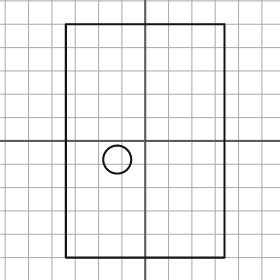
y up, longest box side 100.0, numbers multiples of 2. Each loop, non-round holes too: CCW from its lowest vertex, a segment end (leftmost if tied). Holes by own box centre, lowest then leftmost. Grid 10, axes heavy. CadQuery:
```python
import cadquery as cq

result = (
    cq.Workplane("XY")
    .moveTo(-34.0, -50.0)
    .lineTo(34.0, -50.0)
    .lineTo(34.0, 50.0)
    .lineTo(-34.0, 50.0)
    .close()
    .moveTo(-12.0, -8.0)
    .circle(6.0)
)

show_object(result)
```